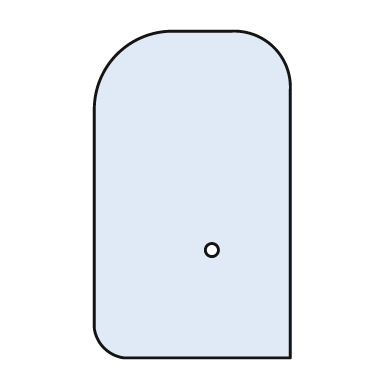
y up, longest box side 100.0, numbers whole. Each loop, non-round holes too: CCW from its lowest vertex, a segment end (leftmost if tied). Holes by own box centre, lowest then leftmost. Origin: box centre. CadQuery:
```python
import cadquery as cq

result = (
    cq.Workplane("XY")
    .moveTo(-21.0, -50.0)
    .lineTo(30.0, -50.0)
    .lineTo(30.0, 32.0)
    .threePointArc((25.0, 45.0), (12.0, 50.0))
    .lineTo(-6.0, 50.0)
    .threePointArc((-23.0, 43.0), (-30.0, 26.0))
    .lineTo(-30.0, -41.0)
    .threePointArc((-27.0, -47.0), (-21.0, -50.0))
    .close()
    .moveTo(6.0, -17.0)
    .circle(2.0)
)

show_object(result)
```